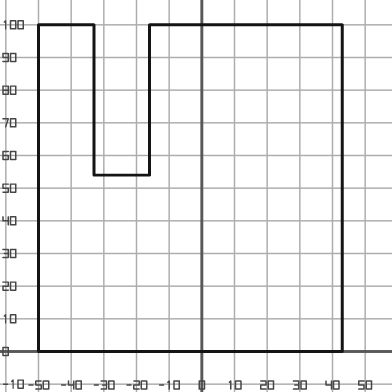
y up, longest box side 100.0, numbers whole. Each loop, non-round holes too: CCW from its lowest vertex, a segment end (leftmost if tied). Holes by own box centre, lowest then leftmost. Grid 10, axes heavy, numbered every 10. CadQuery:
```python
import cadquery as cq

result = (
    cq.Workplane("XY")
    .moveTo(-50.0, 0.0)
    .lineTo(43.0, 0.0)
    .lineTo(43.0, 100.0)
    .lineTo(-16.0, 100.0)
    .lineTo(-16.0, 54.0)
    .lineTo(-33.0, 54.0)
    .lineTo(-33.0, 100.0)
    .lineTo(-50.0, 100.0)
    .close()
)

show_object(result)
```